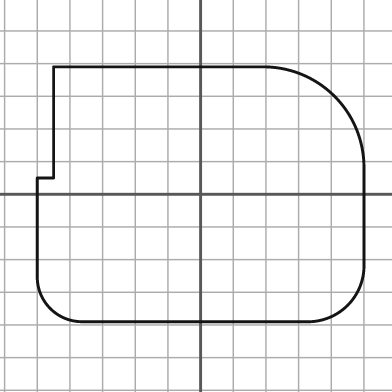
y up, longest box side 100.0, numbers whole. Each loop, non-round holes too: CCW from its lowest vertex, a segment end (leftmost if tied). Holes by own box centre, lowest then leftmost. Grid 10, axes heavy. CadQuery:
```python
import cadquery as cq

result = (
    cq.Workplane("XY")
    .moveTo(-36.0, -39.0)
    .lineTo(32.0, -39.0)
    .threePointArc((45.0, -34.0), (50.0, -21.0))
    .lineTo(50.0, 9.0)
    .threePointArc((41.0, 30.0), (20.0, 39.0))
    .lineTo(-45.0, 39.0)
    .lineTo(-45.0, 5.0)
    .lineTo(-50.0, 5.0)
    .lineTo(-50.0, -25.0)
    .threePointArc((-46.0, -35.0), (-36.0, -39.0))
    .close()
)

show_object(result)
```